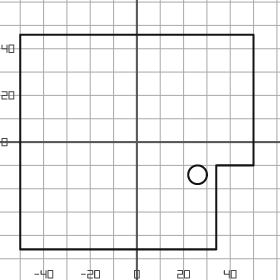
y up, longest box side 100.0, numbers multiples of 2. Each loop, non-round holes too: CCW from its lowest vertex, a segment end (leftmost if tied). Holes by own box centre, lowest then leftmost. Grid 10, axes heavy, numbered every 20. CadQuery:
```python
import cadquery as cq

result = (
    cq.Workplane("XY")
    .moveTo(-50.0, -46.0)
    .lineTo(34.0, -46.0)
    .lineTo(34.0, -10.0)
    .lineTo(50.0, -10.0)
    .lineTo(50.0, 46.0)
    .lineTo(-50.0, 46.0)
    .close()
    .moveTo(26.0, -14.0)
    .circle(4.0)
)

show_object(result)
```